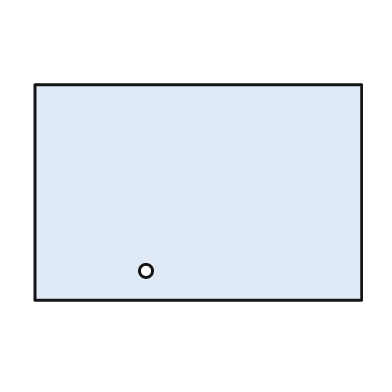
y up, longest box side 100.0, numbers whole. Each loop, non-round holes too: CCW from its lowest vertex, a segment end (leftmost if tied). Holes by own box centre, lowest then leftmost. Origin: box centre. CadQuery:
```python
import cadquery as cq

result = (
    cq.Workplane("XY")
    .moveTo(-50.0, -33.0)
    .lineTo(50.0, -33.0)
    .lineTo(50.0, 33.0)
    .lineTo(-50.0, 33.0)
    .close()
    .moveTo(-16.0, -24.0)
    .circle(2.0)
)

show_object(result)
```